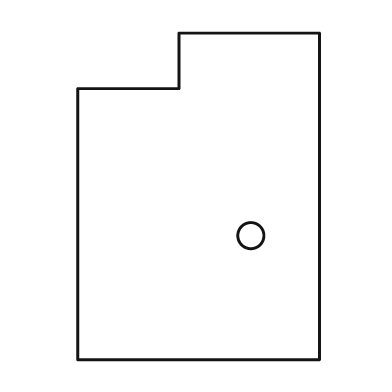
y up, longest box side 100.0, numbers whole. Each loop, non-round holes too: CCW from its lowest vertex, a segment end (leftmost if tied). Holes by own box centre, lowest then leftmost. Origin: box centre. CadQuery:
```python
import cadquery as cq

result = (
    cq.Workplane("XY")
    .moveTo(-37.0, -50.0)
    .lineTo(37.0, -50.0)
    .lineTo(37.0, 50.0)
    .lineTo(-6.0, 50.0)
    .lineTo(-6.0, 33.0)
    .lineTo(-37.0, 33.0)
    .close()
    .moveTo(16.0, -12.0)
    .circle(4.0)
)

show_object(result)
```